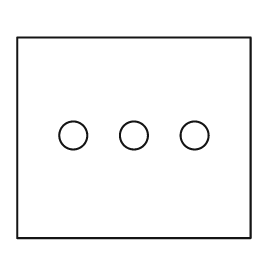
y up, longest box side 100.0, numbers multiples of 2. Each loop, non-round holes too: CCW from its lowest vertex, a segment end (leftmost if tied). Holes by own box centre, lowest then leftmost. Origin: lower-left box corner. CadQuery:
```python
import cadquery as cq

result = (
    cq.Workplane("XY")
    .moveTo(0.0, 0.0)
    .lineTo(100.0, 0.0)
    .lineTo(100.0, 86.0)
    .lineTo(0.0, 86.0)
    .close()
    .moveTo(24.0, 44.0)
    .circle(6.0)
    .moveTo(50.0, 44.0)
    .circle(6.0)
    .moveTo(76.0, 44.0)
    .circle(6.0)
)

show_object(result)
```